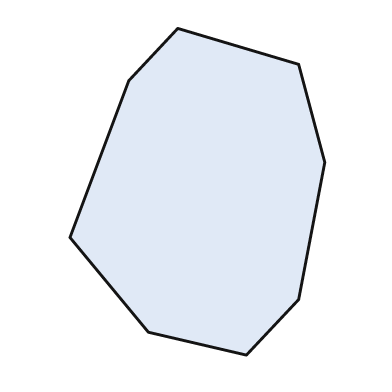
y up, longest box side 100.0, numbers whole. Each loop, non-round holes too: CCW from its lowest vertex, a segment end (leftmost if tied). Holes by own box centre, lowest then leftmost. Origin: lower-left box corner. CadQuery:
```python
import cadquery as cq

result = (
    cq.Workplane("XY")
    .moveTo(54.0, 0.0)
    .lineTo(70.0, 17.0)
    .lineTo(78.0, 59.0)
    .lineTo(70.0, 89.0)
    .lineTo(33.0, 100.0)
    .lineTo(18.0, 84.0)
    .lineTo(0.0, 36.0)
    .lineTo(24.0, 7.0)
    .close()
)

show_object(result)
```